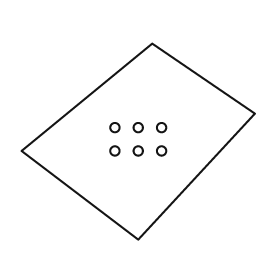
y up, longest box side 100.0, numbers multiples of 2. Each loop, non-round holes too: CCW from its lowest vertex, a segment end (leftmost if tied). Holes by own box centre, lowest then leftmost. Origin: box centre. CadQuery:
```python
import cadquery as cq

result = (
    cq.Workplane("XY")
    .moveTo(0.0, -42.0)
    .lineTo(50.0, 12.0)
    .lineTo(6.0, 42.0)
    .lineTo(-50.0, -4.0)
    .close()
    .moveTo(-10.0, -4.0)
    .circle(2.0)
    .moveTo(0.0, -4.0)
    .circle(2.0)
    .moveTo(10.0, -4.0)
    .circle(2.0)
    .moveTo(-10.0, 6.0)
    .circle(2.0)
    .moveTo(0.0, 6.0)
    .circle(2.0)
    .moveTo(10.0, 6.0)
    .circle(2.0)
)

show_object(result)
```